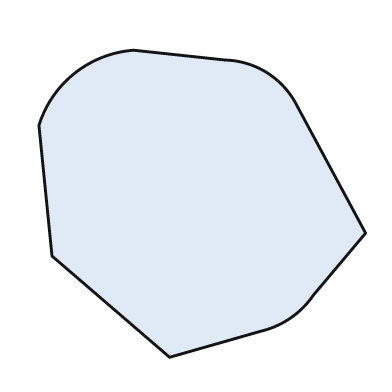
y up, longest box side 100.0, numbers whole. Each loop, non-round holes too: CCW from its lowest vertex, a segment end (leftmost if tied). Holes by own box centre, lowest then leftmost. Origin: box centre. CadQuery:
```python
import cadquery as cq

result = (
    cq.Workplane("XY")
    .moveTo(-10.0, -47.0)
    .lineTo(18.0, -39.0)
    .threePointArc((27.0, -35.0), (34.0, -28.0))
    .lineTo(50.0, -9.0)
    .lineTo(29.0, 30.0)
    .threePointArc((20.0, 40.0), (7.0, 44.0))
    .lineTo(-21.0, 47.0)
    .threePointArc((-39.0, 40.0), (-50.0, 24.0))
    .lineTo(-46.0, -16.0)
    .close()
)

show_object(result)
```